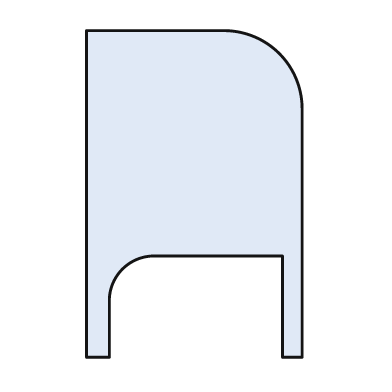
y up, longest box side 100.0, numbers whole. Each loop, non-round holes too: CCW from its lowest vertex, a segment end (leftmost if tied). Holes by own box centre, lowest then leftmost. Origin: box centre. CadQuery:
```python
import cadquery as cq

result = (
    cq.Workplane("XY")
    .moveTo(-33.0, -50.0)
    .lineTo(-26.0, -50.0)
    .lineTo(-26.0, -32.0)
    .threePointArc((-22.0, -23.0), (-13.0, -19.0))
    .lineTo(27.0, -19.0)
    .lineTo(27.0, -50.0)
    .lineTo(33.0, -50.0)
    .lineTo(33.0, 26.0)
    .threePointArc((26.0, 43.0), (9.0, 50.0))
    .lineTo(-33.0, 50.0)
    .close()
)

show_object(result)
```